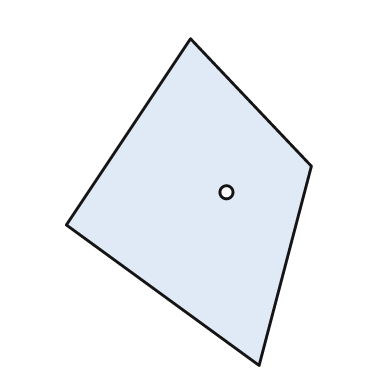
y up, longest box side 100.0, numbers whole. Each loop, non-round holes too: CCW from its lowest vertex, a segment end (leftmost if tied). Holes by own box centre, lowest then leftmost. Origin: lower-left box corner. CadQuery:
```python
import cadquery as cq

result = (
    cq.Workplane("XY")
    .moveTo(59.0, 0.0)
    .lineTo(75.0, 61.0)
    .lineTo(38.0, 100.0)
    .lineTo(0.0, 43.0)
    .close()
    .moveTo(49.0, 53.0)
    .circle(2.0)
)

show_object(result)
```